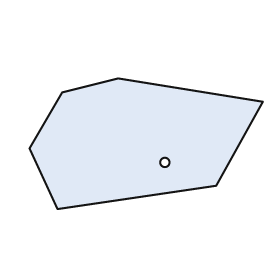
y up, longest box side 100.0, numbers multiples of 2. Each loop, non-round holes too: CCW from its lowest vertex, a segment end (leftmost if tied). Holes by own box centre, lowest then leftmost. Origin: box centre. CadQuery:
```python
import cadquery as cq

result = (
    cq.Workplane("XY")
    .moveTo(-38.0, -28.0)
    .lineTo(30.0, -18.0)
    .lineTo(50.0, 18.0)
    .lineTo(-12.0, 28.0)
    .lineTo(-36.0, 22.0)
    .lineTo(-50.0, -2.0)
    .close()
    .moveTo(8.0, -8.0)
    .circle(2.0)
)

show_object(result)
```